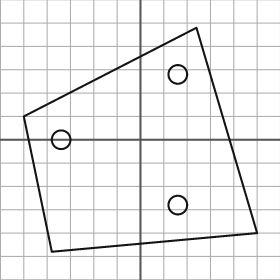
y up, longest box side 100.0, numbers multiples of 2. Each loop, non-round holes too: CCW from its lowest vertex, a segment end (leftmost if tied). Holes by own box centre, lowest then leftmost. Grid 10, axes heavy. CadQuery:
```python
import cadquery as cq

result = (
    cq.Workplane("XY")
    .moveTo(-38.0, -48.0)
    .lineTo(50.0, -40.0)
    .lineTo(24.0, 48.0)
    .lineTo(-50.0, 10.0)
    .close()
    .moveTo(16.0, -28.0)
    .circle(4.0)
    .moveTo(-34.0, 0.0)
    .circle(4.0)
    .moveTo(16.0, 28.0)
    .circle(4.0)
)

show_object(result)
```